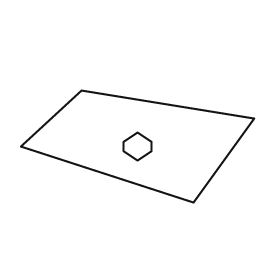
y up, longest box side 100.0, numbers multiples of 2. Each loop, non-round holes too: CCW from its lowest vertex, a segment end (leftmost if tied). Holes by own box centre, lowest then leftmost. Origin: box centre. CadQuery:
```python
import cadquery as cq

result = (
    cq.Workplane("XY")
    .moveTo(24.0, -24.0)
    .lineTo(50.0, 12.0)
    .lineTo(-24.0, 24.0)
    .lineTo(-50.0, 0.0)
    .close()
    .moveTo(0.0, -6.0)
    .lineTo(6.0, -2.0)
    .lineTo(6.0, 2.0)
    .lineTo(0.0, 6.0)
    .lineTo(-6.0, 2.0)
    .lineTo(-6.0, -2.0)
    .close()
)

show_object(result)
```